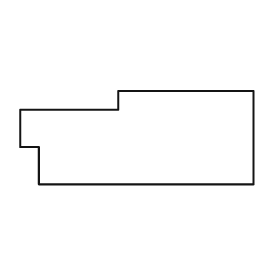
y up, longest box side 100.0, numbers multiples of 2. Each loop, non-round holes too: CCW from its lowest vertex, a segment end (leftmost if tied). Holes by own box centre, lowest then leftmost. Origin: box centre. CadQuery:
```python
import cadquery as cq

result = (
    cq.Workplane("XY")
    .moveTo(-42.0, -20.0)
    .lineTo(50.0, -20.0)
    .lineTo(50.0, 20.0)
    .lineTo(-8.0, 20.0)
    .lineTo(-8.0, 12.0)
    .lineTo(-50.0, 12.0)
    .lineTo(-50.0, -4.0)
    .lineTo(-42.0, -4.0)
    .close()
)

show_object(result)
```